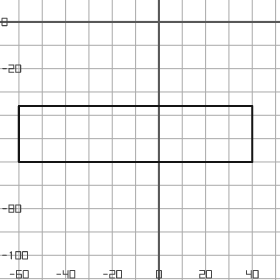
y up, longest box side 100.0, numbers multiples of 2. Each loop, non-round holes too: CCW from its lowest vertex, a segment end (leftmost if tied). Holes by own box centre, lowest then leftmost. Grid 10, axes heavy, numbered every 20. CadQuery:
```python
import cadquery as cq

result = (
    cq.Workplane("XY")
    .moveTo(-60.0, -60.0)
    .lineTo(40.0, -60.0)
    .lineTo(40.0, -36.0)
    .lineTo(-60.0, -36.0)
    .close()
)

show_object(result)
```